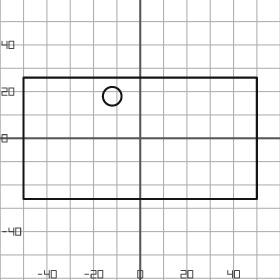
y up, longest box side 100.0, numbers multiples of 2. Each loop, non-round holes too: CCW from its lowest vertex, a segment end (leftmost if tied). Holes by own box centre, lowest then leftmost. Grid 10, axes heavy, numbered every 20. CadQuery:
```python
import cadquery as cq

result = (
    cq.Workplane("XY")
    .moveTo(-50.0, -26.0)
    .lineTo(50.0, -26.0)
    .lineTo(50.0, 26.0)
    .lineTo(-50.0, 26.0)
    .close()
    .moveTo(-12.0, 18.0)
    .circle(4.0)
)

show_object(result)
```